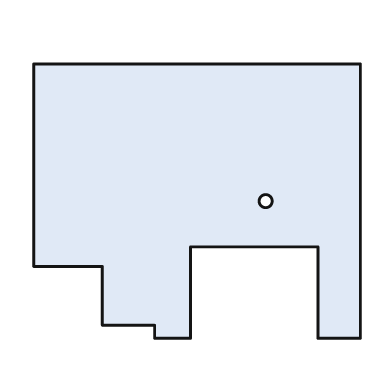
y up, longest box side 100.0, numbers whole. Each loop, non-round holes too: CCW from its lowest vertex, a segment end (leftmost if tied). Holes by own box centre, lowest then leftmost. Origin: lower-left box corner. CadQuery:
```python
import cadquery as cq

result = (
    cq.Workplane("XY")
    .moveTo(37.0, 0.0)
    .lineTo(48.0, 0.0)
    .lineTo(48.0, 28.0)
    .lineTo(87.0, 28.0)
    .lineTo(87.0, 0.0)
    .lineTo(100.0, 0.0)
    .lineTo(100.0, 84.0)
    .lineTo(0.0, 84.0)
    .lineTo(0.0, 22.0)
    .lineTo(21.0, 22.0)
    .lineTo(21.0, 4.0)
    .lineTo(37.0, 4.0)
    .close()
    .moveTo(71.0, 42.0)
    .circle(2.0)
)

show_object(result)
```